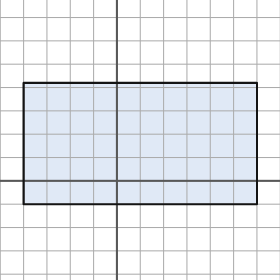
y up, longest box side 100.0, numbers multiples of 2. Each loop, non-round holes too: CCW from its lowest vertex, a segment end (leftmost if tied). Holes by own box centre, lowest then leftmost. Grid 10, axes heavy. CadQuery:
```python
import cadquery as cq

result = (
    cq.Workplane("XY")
    .moveTo(-40.0, -10.0)
    .lineTo(60.0, -10.0)
    .lineTo(60.0, 42.0)
    .lineTo(-40.0, 42.0)
    .close()
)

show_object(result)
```